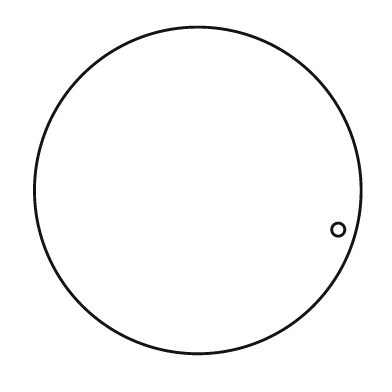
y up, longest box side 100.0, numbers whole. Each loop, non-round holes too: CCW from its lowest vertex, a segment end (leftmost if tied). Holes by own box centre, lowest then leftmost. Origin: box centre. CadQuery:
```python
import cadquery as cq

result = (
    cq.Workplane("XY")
    .moveTo(0.0, 0.0)
    .circle(50.0)
    .moveTo(43.0, -12.0)
    .circle(2.0)
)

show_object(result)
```